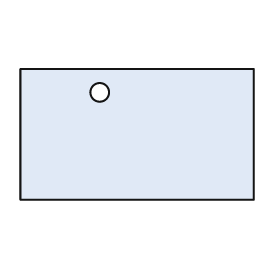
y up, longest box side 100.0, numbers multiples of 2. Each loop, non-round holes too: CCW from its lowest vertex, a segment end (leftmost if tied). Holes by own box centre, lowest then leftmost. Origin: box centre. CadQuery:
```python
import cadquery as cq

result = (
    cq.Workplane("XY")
    .moveTo(-50.0, -28.0)
    .lineTo(50.0, -28.0)
    .lineTo(50.0, 28.0)
    .lineTo(-50.0, 28.0)
    .close()
    .moveTo(-16.0, 18.0)
    .circle(4.0)
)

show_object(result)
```